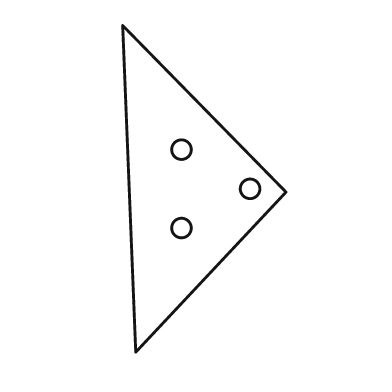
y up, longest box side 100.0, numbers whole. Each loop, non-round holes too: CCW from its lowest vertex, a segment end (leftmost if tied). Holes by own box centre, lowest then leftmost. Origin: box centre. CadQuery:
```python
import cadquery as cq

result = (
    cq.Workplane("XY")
    .moveTo(-21.0, -50.0)
    .lineTo(25.0, -1.0)
    .lineTo(-25.0, 50.0)
    .close()
    .moveTo(-7.0, -12.0)
    .circle(3.0)
    .moveTo(14.0, 0.0)
    .circle(3.0)
    .moveTo(-7.0, 12.0)
    .circle(3.0)
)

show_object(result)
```